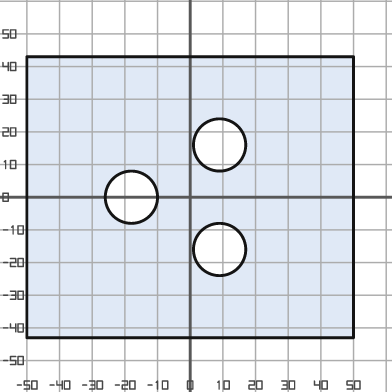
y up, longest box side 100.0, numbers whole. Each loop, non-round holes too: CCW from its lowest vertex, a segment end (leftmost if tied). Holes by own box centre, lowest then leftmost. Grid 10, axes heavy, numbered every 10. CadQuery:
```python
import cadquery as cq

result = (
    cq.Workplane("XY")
    .moveTo(-50.0, -43.0)
    .lineTo(50.0, -43.0)
    .lineTo(50.0, 43.0)
    .lineTo(-50.0, 43.0)
    .close()
    .moveTo(9.0, -16.0)
    .circle(8.0)
    .moveTo(-18.0, 0.0)
    .circle(8.0)
    .moveTo(9.0, 16.0)
    .circle(8.0)
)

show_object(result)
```